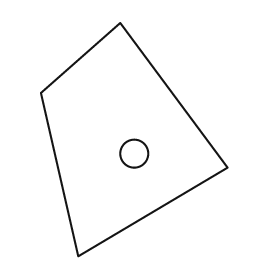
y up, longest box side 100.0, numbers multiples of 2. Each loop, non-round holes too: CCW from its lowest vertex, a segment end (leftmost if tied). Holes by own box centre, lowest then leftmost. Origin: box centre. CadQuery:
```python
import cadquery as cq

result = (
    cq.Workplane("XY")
    .moveTo(-24.0, -50.0)
    .lineTo(40.0, -12.0)
    .lineTo(-6.0, 50.0)
    .lineTo(-40.0, 20.0)
    .close()
    .moveTo(0.0, -6.0)
    .circle(6.0)
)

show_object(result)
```